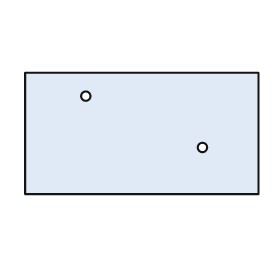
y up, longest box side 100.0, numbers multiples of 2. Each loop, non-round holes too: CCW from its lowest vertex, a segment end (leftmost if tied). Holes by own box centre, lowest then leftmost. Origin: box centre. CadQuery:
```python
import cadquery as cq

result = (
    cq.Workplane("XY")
    .moveTo(-50.0, -26.0)
    .lineTo(50.0, -26.0)
    .lineTo(50.0, 26.0)
    .lineTo(-50.0, 26.0)
    .close()
    .moveTo(26.0, -6.0)
    .circle(2.0)
    .moveTo(-24.0, 16.0)
    .circle(2.0)
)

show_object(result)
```